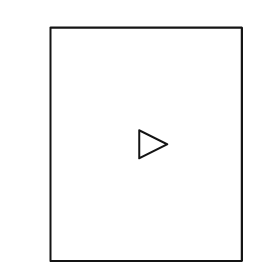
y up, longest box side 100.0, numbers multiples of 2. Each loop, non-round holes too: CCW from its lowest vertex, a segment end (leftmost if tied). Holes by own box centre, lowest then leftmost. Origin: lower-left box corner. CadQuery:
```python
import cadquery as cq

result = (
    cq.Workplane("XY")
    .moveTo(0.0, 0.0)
    .lineTo(82.0, 0.0)
    .lineTo(82.0, 100.0)
    .lineTo(0.0, 100.0)
    .close()
    .moveTo(38.0, 44.0)
    .lineTo(50.0, 50.0)
    .lineTo(38.0, 56.0)
    .close()
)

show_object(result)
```